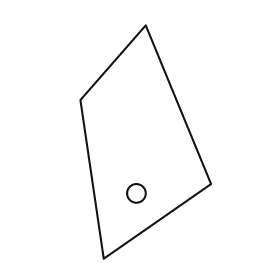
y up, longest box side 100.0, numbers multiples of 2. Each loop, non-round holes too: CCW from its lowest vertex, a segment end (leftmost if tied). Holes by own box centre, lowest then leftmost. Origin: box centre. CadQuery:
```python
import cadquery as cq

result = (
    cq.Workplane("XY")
    .moveTo(-18.0, -50.0)
    .lineTo(28.0, -18.0)
    .lineTo(0.0, 50.0)
    .lineTo(-28.0, 18.0)
    .close()
    .moveTo(-4.0, -22.0)
    .circle(4.0)
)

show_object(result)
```